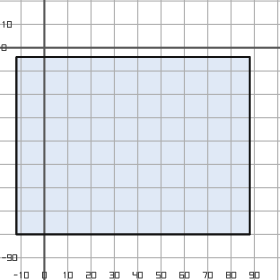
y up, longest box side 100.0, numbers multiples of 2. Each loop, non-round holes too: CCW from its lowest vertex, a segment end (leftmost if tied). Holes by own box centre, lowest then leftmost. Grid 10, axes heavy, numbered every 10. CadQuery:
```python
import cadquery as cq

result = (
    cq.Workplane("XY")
    .moveTo(-12.0, -80.0)
    .lineTo(88.0, -80.0)
    .lineTo(88.0, -4.0)
    .lineTo(-12.0, -4.0)
    .close()
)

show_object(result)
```